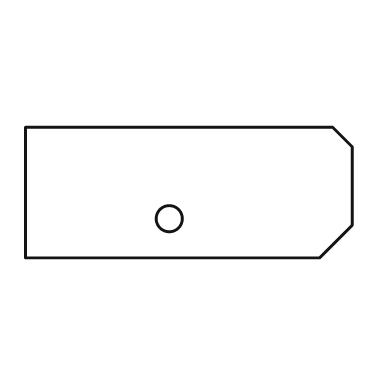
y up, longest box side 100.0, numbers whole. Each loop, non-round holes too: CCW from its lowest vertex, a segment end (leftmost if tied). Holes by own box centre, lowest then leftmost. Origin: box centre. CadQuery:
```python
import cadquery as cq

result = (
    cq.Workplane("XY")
    .moveTo(-50.0, -20.0)
    .lineTo(40.0, -20.0)
    .lineTo(50.0, -10.0)
    .lineTo(50.0, 14.0)
    .lineTo(44.0, 20.0)
    .lineTo(-50.0, 20.0)
    .close()
    .moveTo(-6.0, -8.0)
    .circle(4.0)
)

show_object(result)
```